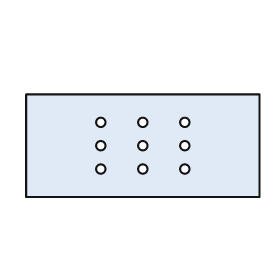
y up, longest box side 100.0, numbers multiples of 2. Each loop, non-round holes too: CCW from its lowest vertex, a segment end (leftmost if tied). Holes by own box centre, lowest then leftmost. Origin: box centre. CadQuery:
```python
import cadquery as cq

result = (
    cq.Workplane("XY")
    .moveTo(-50.0, -22.0)
    .lineTo(50.0, -22.0)
    .lineTo(50.0, 22.0)
    .lineTo(-50.0, 22.0)
    .close()
    .moveTo(-18.0, -10.0)
    .circle(2.0)
    .moveTo(0.0, -10.0)
    .circle(2.0)
    .moveTo(18.0, -10.0)
    .circle(2.0)
    .moveTo(-18.0, 0.0)
    .circle(2.0)
    .moveTo(0.0, 0.0)
    .circle(2.0)
    .moveTo(18.0, 0.0)
    .circle(2.0)
    .moveTo(-18.0, 10.0)
    .circle(2.0)
    .moveTo(0.0, 10.0)
    .circle(2.0)
    .moveTo(18.0, 10.0)
    .circle(2.0)
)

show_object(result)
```